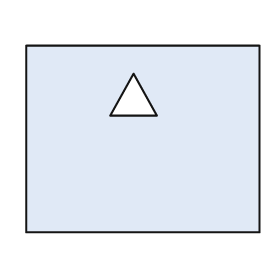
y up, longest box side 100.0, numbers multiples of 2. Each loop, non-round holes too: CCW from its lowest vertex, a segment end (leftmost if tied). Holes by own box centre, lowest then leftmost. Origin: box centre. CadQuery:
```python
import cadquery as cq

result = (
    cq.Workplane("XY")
    .moveTo(-50.0, -40.0)
    .lineTo(50.0, -40.0)
    .lineTo(50.0, 40.0)
    .lineTo(-50.0, 40.0)
    .close()
    .moveTo(-14.0, 10.0)
    .lineTo(6.0, 10.0)
    .lineTo(-4.0, 28.0)
    .close()
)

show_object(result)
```